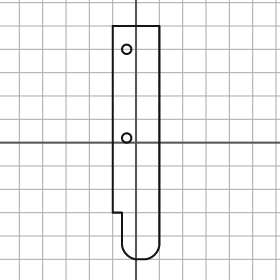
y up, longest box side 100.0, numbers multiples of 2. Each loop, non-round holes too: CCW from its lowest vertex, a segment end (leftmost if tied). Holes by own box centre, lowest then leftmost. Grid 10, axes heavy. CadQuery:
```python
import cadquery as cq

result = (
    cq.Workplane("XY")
    .moveTo(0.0, -50.0)
    .lineTo(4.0, -50.0)
    .threePointArc((8.0, -48.0), (10.0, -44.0))
    .lineTo(10.0, 50.0)
    .lineTo(-10.0, 50.0)
    .lineTo(-10.0, -30.0)
    .lineTo(-6.0, -30.0)
    .lineTo(-6.0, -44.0)
    .threePointArc((-4.0, -48.0), (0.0, -50.0))
    .close()
    .moveTo(-4.0, 2.0)
    .circle(2.0)
    .moveTo(-4.0, 40.0)
    .circle(2.0)
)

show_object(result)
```